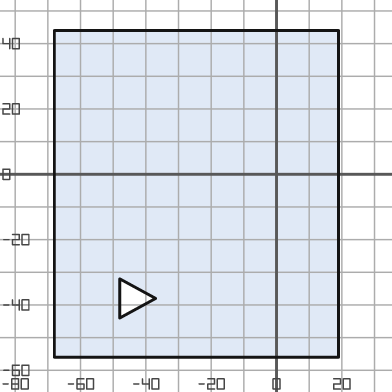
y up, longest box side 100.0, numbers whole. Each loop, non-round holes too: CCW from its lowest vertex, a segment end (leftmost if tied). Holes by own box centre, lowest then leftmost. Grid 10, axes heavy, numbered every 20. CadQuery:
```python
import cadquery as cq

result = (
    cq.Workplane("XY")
    .moveTo(-68.0, -56.0)
    .lineTo(19.0, -56.0)
    .lineTo(19.0, 44.0)
    .lineTo(-68.0, 44.0)
    .close()
    .moveTo(-48.0, -44.0)
    .lineTo(-37.0, -38.0)
    .lineTo(-48.0, -32.0)
    .close()
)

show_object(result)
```